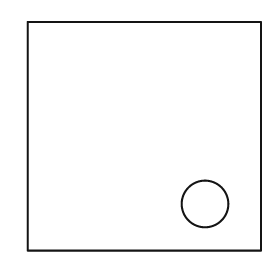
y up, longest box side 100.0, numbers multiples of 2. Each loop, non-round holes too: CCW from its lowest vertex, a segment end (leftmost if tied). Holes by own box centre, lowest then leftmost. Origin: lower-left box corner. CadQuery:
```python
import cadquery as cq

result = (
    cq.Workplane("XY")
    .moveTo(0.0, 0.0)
    .lineTo(100.0, 0.0)
    .lineTo(100.0, 98.0)
    .lineTo(0.0, 98.0)
    .close()
    .moveTo(76.0, 20.0)
    .circle(10.0)
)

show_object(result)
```